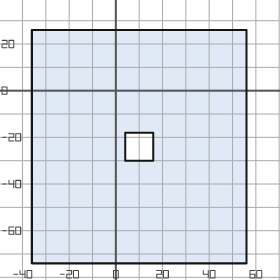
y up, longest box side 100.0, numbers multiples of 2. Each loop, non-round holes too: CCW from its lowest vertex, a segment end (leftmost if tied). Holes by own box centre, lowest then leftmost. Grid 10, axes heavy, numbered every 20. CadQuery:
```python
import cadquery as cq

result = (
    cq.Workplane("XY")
    .moveTo(-36.0, -74.0)
    .lineTo(56.0, -74.0)
    .lineTo(56.0, 26.0)
    .lineTo(-36.0, 26.0)
    .close()
    .moveTo(4.0, -30.0)
    .lineTo(16.0, -30.0)
    .lineTo(16.0, -18.0)
    .lineTo(4.0, -18.0)
    .close()
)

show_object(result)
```